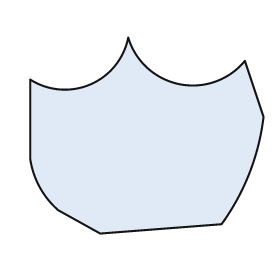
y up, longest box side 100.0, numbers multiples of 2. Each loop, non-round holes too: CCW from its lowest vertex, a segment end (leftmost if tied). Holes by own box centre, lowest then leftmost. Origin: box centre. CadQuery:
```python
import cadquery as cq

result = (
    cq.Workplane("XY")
    .moveTo(-20.0, -42.0)
    .lineTo(32.0, -38.0)
    .threePointArc((44.0, -16.0), (50.0, 8.0))
    .lineTo(42.0, 32.0)
    .threePointArc((14.0, 22.0), (-8.0, 42.0))
    .threePointArc((-24.0, 22.0), (-50.0, 24.0))
    .lineTo(-50.0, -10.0)
    .threePointArc((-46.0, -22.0), (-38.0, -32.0))
    .close()
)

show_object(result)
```